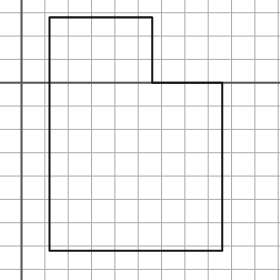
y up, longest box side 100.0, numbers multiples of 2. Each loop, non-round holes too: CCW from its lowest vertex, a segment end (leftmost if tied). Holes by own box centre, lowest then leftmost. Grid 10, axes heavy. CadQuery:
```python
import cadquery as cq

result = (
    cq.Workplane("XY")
    .moveTo(12.0, -72.0)
    .lineTo(86.0, -72.0)
    .lineTo(86.0, 0.0)
    .lineTo(56.0, 0.0)
    .lineTo(56.0, 28.0)
    .lineTo(12.0, 28.0)
    .close()
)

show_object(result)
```